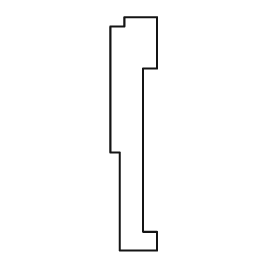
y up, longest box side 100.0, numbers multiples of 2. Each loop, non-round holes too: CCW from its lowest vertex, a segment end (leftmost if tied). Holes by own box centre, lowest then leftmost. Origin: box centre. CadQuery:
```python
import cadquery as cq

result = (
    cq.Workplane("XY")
    .moveTo(-6.0, -50.0)
    .lineTo(10.0, -50.0)
    .lineTo(10.0, -42.0)
    .lineTo(4.0, -42.0)
    .lineTo(4.0, 28.0)
    .lineTo(10.0, 28.0)
    .lineTo(10.0, 50.0)
    .lineTo(-4.0, 50.0)
    .lineTo(-4.0, 46.0)
    .lineTo(-10.0, 46.0)
    .lineTo(-10.0, -8.0)
    .lineTo(-6.0, -8.0)
    .close()
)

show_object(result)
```